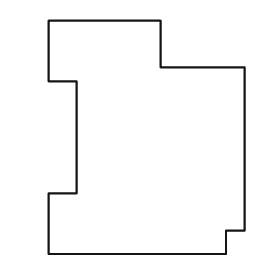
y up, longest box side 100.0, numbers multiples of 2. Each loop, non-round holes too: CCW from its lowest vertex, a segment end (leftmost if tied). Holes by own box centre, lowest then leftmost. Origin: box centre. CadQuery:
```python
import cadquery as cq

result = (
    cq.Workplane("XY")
    .moveTo(-42.0, -50.0)
    .lineTo(34.0, -50.0)
    .lineTo(34.0, -40.0)
    .lineTo(42.0, -40.0)
    .lineTo(42.0, 30.0)
    .lineTo(6.0, 30.0)
    .lineTo(6.0, 50.0)
    .lineTo(-42.0, 50.0)
    .lineTo(-42.0, 24.0)
    .lineTo(-30.0, 24.0)
    .lineTo(-30.0, -24.0)
    .lineTo(-42.0, -24.0)
    .close()
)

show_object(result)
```